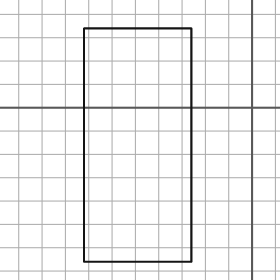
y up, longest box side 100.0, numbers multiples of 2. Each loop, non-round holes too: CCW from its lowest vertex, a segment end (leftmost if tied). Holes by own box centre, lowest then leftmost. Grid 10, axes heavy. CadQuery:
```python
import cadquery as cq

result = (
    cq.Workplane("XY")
    .moveTo(-72.0, -66.0)
    .lineTo(-26.0, -66.0)
    .lineTo(-26.0, 34.0)
    .lineTo(-72.0, 34.0)
    .close()
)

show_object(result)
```